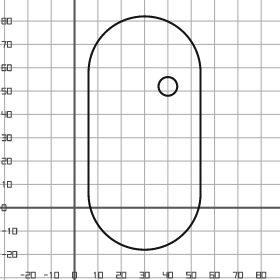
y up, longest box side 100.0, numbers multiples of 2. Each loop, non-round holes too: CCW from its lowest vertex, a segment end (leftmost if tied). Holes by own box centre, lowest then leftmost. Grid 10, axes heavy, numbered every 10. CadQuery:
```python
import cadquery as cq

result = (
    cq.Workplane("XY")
    .moveTo(6.0, 6.0)
    .threePointArc((30.0, -18.0), (54.0, 6.0))
    .lineTo(54.0, 58.0)
    .threePointArc((30.0, 82.0), (6.0, 58.0))
    .close()
    .moveTo(40.0, 52.0)
    .circle(4.0)
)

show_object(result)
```